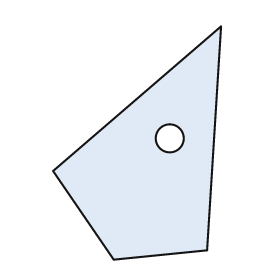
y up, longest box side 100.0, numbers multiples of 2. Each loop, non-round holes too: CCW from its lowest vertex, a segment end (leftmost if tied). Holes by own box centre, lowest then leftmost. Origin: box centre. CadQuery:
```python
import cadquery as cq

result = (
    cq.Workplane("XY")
    .moveTo(-10.0, -50.0)
    .lineTo(30.0, -46.0)
    .lineTo(36.0, 50.0)
    .lineTo(-36.0, -12.0)
    .close()
    .moveTo(14.0, 2.0)
    .circle(6.0)
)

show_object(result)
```